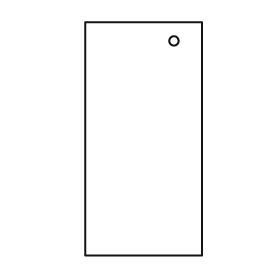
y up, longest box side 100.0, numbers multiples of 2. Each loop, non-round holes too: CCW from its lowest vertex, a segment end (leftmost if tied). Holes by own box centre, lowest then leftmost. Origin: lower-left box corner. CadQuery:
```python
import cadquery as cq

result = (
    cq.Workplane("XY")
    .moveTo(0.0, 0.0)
    .lineTo(50.0, 0.0)
    .lineTo(50.0, 100.0)
    .lineTo(0.0, 100.0)
    .close()
    .moveTo(38.0, 92.0)
    .circle(2.0)
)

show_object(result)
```